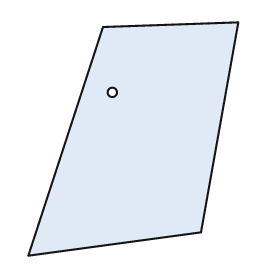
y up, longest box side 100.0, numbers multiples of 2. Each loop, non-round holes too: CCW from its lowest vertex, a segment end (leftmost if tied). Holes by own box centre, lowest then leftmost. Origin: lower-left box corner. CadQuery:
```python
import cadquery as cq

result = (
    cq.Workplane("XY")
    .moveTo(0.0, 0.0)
    .lineTo(74.0, 10.0)
    .lineTo(90.0, 100.0)
    .lineTo(32.0, 98.0)
    .close()
    .moveTo(36.0, 70.0)
    .circle(2.0)
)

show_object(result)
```